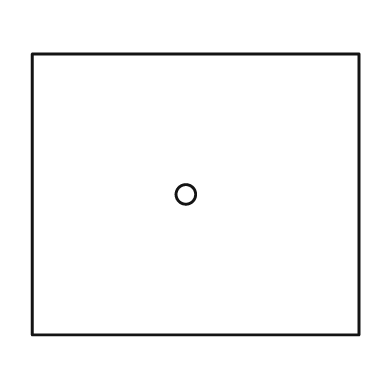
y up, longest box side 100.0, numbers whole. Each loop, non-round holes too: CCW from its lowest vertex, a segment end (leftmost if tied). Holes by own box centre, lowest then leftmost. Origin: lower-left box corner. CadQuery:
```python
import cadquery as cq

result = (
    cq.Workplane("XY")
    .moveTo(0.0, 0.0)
    .lineTo(100.0, 0.0)
    .lineTo(100.0, 86.0)
    .lineTo(0.0, 86.0)
    .close()
    .moveTo(47.0, 43.0)
    .circle(3.0)
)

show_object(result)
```